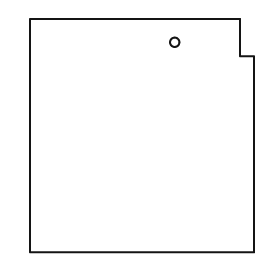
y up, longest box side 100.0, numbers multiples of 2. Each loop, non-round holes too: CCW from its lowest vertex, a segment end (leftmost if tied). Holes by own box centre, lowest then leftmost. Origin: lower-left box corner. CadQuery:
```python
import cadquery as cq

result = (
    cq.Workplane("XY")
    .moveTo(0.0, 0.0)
    .lineTo(96.0, 0.0)
    .lineTo(96.0, 84.0)
    .lineTo(90.0, 84.0)
    .lineTo(90.0, 100.0)
    .lineTo(0.0, 100.0)
    .close()
    .moveTo(62.0, 90.0)
    .circle(2.0)
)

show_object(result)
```